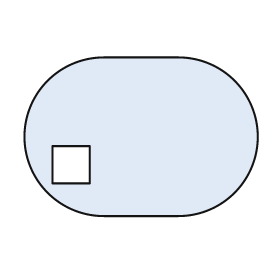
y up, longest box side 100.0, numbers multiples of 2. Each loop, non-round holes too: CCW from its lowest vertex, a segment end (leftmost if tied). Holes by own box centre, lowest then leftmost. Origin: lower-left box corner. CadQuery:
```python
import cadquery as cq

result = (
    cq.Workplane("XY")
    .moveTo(34.0, 0.0)
    .lineTo(66.0, 0.0)
    .threePointArc((100.0, 34.0), (66.0, 68.0))
    .lineTo(34.0, 68.0)
    .threePointArc((0.0, 34.0), (34.0, 0.0))
    .close()
    .moveTo(12.0, 14.0)
    .lineTo(28.0, 14.0)
    .lineTo(28.0, 30.0)
    .lineTo(12.0, 30.0)
    .close()
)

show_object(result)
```